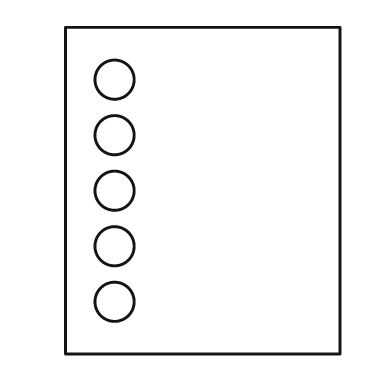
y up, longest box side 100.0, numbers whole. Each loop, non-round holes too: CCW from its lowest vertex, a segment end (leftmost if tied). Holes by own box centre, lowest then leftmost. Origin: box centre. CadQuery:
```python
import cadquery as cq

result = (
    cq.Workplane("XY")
    .moveTo(-42.0, -50.0)
    .lineTo(42.0, -50.0)
    .lineTo(42.0, 50.0)
    .lineTo(-42.0, 50.0)
    .close()
    .moveTo(-27.0, -34.0)
    .circle(6.0)
    .moveTo(-27.0, -17.0)
    .circle(6.0)
    .moveTo(-27.0, 0.0)
    .circle(6.0)
    .moveTo(-27.0, 17.0)
    .circle(6.0)
    .moveTo(-27.0, 34.0)
    .circle(6.0)
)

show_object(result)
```